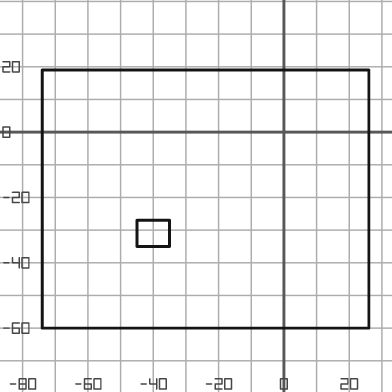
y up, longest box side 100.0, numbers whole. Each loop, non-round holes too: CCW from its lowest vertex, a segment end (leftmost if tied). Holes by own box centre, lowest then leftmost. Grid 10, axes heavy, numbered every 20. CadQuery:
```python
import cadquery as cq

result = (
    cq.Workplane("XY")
    .moveTo(-74.0, -60.0)
    .lineTo(26.0, -60.0)
    .lineTo(26.0, 19.0)
    .lineTo(-74.0, 19.0)
    .close()
    .moveTo(-45.0, -35.0)
    .lineTo(-35.0, -35.0)
    .lineTo(-35.0, -27.0)
    .lineTo(-45.0, -27.0)
    .close()
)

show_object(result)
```